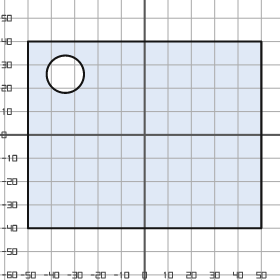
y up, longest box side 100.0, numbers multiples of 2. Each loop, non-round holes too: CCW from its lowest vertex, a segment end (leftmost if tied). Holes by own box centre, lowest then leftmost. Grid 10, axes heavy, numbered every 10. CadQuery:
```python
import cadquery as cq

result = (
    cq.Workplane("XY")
    .moveTo(-50.0, -40.0)
    .lineTo(50.0, -40.0)
    .lineTo(50.0, 40.0)
    .lineTo(-50.0, 40.0)
    .close()
    .moveTo(-34.0, 26.0)
    .circle(8.0)
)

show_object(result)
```